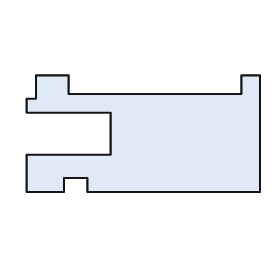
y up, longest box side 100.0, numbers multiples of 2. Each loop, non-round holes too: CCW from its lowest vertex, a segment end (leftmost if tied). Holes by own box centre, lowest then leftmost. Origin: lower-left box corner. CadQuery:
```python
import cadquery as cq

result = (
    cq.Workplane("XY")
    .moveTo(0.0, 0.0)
    .lineTo(16.0, 0.0)
    .lineTo(16.0, 6.0)
    .lineTo(26.0, 6.0)
    .lineTo(26.0, 0.0)
    .lineTo(100.0, 0.0)
    .lineTo(100.0, 50.0)
    .lineTo(92.0, 50.0)
    .lineTo(92.0, 42.0)
    .lineTo(18.0, 42.0)
    .lineTo(18.0, 50.0)
    .lineTo(4.0, 50.0)
    .lineTo(4.0, 40.0)
    .lineTo(0.0, 40.0)
    .lineTo(0.0, 34.0)
    .lineTo(36.0, 34.0)
    .lineTo(36.0, 16.0)
    .lineTo(0.0, 16.0)
    .close()
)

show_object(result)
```